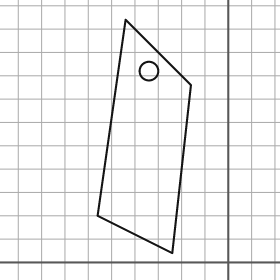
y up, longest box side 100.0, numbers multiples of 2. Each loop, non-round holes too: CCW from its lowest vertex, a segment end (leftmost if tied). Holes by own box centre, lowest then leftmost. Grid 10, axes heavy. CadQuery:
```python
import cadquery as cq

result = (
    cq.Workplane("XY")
    .moveTo(-24.0, 4.0)
    .lineTo(-16.0, 76.0)
    .lineTo(-44.0, 104.0)
    .lineTo(-56.0, 20.0)
    .close()
    .moveTo(-34.0, 82.0)
    .circle(4.0)
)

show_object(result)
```